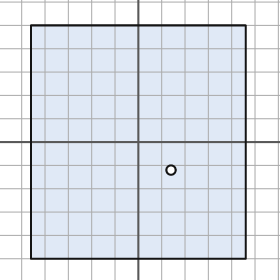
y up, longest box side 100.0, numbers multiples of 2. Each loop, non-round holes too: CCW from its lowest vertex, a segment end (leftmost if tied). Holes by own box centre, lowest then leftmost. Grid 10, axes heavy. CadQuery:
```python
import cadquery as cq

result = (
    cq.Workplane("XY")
    .moveTo(-46.0, -50.0)
    .lineTo(46.0, -50.0)
    .lineTo(46.0, 50.0)
    .lineTo(-46.0, 50.0)
    .close()
    .moveTo(14.0, -12.0)
    .circle(2.0)
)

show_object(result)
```